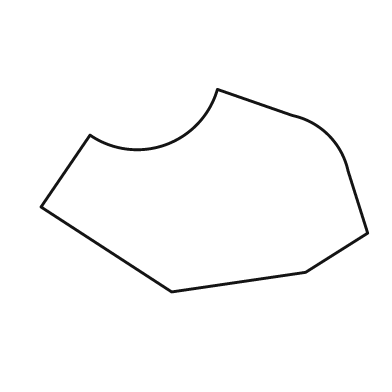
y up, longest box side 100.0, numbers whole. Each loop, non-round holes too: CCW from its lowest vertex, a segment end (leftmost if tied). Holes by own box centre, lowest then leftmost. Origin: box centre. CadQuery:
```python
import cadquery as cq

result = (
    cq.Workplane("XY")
    .moveTo(-10.0, -31.0)
    .lineTo(31.0, -25.0)
    .lineTo(50.0, -13.0)
    .lineTo(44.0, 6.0)
    .threePointArc((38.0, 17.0), (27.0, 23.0))
    .lineTo(4.0, 31.0)
    .threePointArc((-12.0, 14.0), (-35.0, 17.0))
    .lineTo(-50.0, -5.0)
    .close()
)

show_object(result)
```